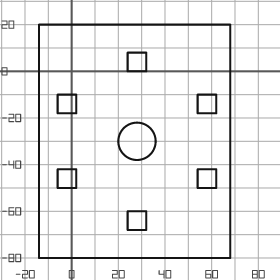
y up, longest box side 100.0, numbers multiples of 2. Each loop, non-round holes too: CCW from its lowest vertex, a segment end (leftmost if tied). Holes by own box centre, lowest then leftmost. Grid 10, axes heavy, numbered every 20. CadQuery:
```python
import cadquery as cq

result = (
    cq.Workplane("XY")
    .moveTo(-14.0, -80.0)
    .lineTo(68.0, -80.0)
    .lineTo(68.0, 20.0)
    .lineTo(-14.0, 20.0)
    .close()
    .moveTo(24.0, -68.0)
    .lineTo(32.0, -68.0)
    .lineTo(32.0, -60.0)
    .lineTo(24.0, -60.0)
    .close()
    .moveTo(-6.0, -50.0)
    .lineTo(2.0, -50.0)
    .lineTo(2.0, -42.0)
    .lineTo(-6.0, -42.0)
    .close()
    .moveTo(54.0, -50.0)
    .lineTo(62.0, -50.0)
    .lineTo(62.0, -42.0)
    .lineTo(54.0, -42.0)
    .close()
    .moveTo(28.0, -30.0)
    .circle(8.0)
    .moveTo(-6.0, -18.0)
    .lineTo(2.0, -18.0)
    .lineTo(2.0, -10.0)
    .lineTo(-6.0, -10.0)
    .close()
    .moveTo(54.0, -18.0)
    .lineTo(62.0, -18.0)
    .lineTo(62.0, -10.0)
    .lineTo(54.0, -10.0)
    .close()
    .moveTo(24.0, 0.0)
    .lineTo(32.0, 0.0)
    .lineTo(32.0, 8.0)
    .lineTo(24.0, 8.0)
    .close()
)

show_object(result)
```